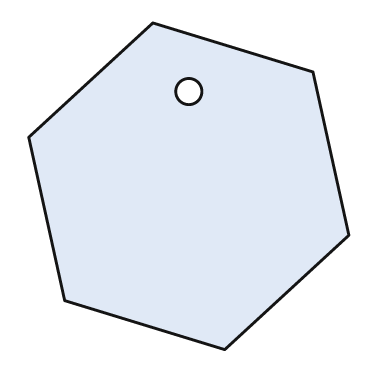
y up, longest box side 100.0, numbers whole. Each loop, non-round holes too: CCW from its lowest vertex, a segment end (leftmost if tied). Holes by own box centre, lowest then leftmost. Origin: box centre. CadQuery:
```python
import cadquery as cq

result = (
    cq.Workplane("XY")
    .moveTo(11.0, -50.0)
    .lineTo(49.0, -15.0)
    .lineTo(38.0, 35.0)
    .lineTo(-11.0, 50.0)
    .lineTo(-49.0, 15.0)
    .lineTo(-38.0, -35.0)
    .close()
    .moveTo(0.0, 29.0)
    .circle(4.0)
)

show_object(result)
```